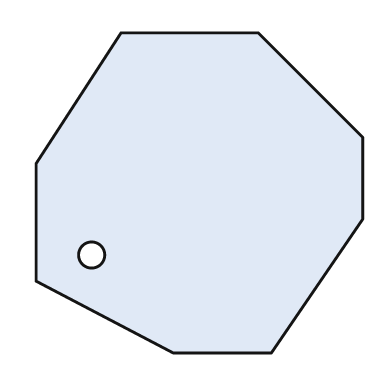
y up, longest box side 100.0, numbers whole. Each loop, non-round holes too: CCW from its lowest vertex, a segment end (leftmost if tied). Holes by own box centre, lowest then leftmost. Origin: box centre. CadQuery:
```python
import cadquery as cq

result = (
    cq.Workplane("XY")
    .moveTo(-8.0, -49.0)
    .lineTo(22.0, -49.0)
    .lineTo(50.0, -8.0)
    .lineTo(50.0, 17.0)
    .lineTo(18.0, 49.0)
    .lineTo(-24.0, 49.0)
    .lineTo(-50.0, 9.0)
    .lineTo(-50.0, -27.0)
    .close()
    .moveTo(-33.0, -19.0)
    .circle(4.0)
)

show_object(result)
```